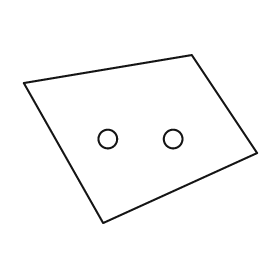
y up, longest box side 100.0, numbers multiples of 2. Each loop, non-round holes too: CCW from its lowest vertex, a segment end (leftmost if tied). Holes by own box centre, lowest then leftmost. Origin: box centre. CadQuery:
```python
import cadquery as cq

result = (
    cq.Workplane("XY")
    .moveTo(-16.0, -36.0)
    .lineTo(50.0, -6.0)
    .lineTo(22.0, 36.0)
    .lineTo(-50.0, 24.0)
    .close()
    .moveTo(-14.0, 0.0)
    .circle(4.0)
    .moveTo(14.0, 0.0)
    .circle(4.0)
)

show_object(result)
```